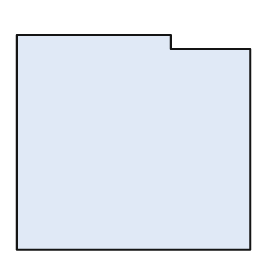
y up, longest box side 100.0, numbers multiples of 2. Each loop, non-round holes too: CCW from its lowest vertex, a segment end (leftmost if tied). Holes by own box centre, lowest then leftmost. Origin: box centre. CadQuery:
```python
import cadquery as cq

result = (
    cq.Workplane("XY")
    .moveTo(-50.0, -46.0)
    .lineTo(50.0, -46.0)
    .lineTo(50.0, 40.0)
    .lineTo(16.0, 40.0)
    .lineTo(16.0, 46.0)
    .lineTo(-50.0, 46.0)
    .close()
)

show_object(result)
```